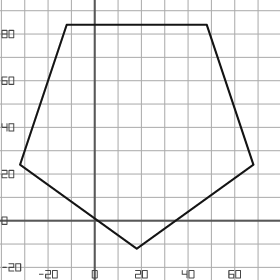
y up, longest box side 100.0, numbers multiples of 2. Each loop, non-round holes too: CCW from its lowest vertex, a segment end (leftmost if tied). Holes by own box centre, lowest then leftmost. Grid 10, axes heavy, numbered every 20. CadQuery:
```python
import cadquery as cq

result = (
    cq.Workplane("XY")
    .moveTo(18.0, -12.0)
    .lineTo(68.0, 24.0)
    .lineTo(48.0, 84.0)
    .lineTo(-12.0, 84.0)
    .lineTo(-32.0, 24.0)
    .close()
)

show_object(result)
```